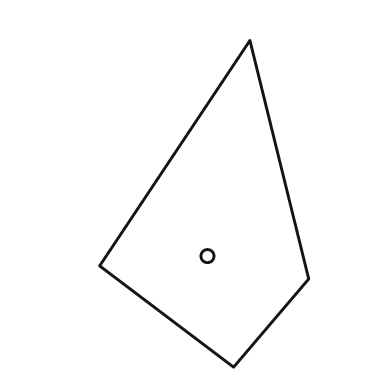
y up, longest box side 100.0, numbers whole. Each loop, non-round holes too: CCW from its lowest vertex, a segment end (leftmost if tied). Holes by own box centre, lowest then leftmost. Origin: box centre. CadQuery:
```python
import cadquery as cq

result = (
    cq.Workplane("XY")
    .moveTo(9.0, -50.0)
    .lineTo(32.0, -23.0)
    .lineTo(14.0, 50.0)
    .lineTo(-32.0, -19.0)
    .close()
    .moveTo(1.0, -16.0)
    .circle(2.0)
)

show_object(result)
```